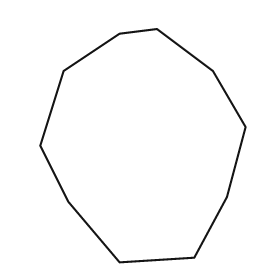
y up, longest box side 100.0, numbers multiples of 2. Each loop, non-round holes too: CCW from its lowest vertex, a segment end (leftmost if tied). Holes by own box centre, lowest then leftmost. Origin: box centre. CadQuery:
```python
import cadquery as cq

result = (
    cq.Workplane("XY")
    .moveTo(-10.0, -50.0)
    .lineTo(22.0, -48.0)
    .lineTo(36.0, -22.0)
    .lineTo(44.0, 8.0)
    .lineTo(30.0, 32.0)
    .lineTo(6.0, 50.0)
    .lineTo(-10.0, 48.0)
    .lineTo(-34.0, 32.0)
    .lineTo(-44.0, 0.0)
    .lineTo(-32.0, -24.0)
    .close()
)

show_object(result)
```